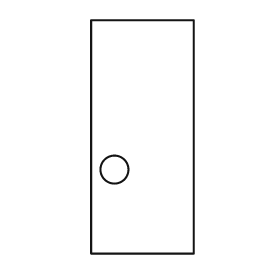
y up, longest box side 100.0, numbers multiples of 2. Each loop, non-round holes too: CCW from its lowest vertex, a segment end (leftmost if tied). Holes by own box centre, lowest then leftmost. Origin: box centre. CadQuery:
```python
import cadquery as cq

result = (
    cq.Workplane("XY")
    .moveTo(-22.0, -50.0)
    .lineTo(22.0, -50.0)
    .lineTo(22.0, 50.0)
    .lineTo(-22.0, 50.0)
    .close()
    .moveTo(-12.0, -14.0)
    .circle(6.0)
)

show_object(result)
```